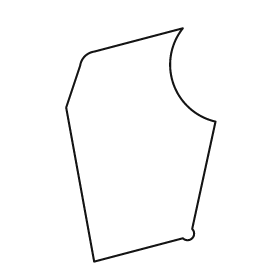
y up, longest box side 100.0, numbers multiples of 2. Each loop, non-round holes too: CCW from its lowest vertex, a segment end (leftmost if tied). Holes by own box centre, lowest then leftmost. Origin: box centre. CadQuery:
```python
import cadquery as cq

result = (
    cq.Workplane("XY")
    .moveTo(-20.0, -50.0)
    .lineTo(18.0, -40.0)
    .threePointArc((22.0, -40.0), (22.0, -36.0))
    .lineTo(32.0, 10.0)
    .threePointArc((14.0, 26.0), (18.0, 50.0))
    .lineTo(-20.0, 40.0)
    .threePointArc((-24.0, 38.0), (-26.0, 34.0))
    .lineTo(-32.0, 16.0)
    .close()
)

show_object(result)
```